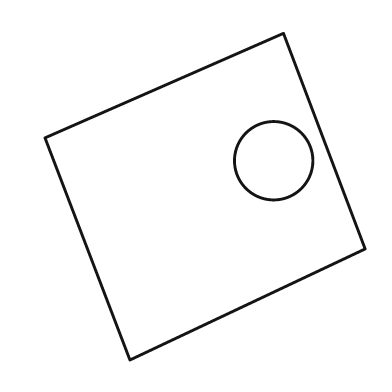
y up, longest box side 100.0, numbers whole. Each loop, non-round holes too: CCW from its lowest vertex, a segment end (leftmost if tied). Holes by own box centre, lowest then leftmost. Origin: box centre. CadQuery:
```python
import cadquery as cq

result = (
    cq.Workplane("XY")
    .moveTo(-23.0, -50.0)
    .lineTo(49.0, -16.0)
    .lineTo(24.0, 50.0)
    .lineTo(-49.0, 18.0)
    .close()
    .moveTo(21.0, 11.0)
    .circle(12.0)
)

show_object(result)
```